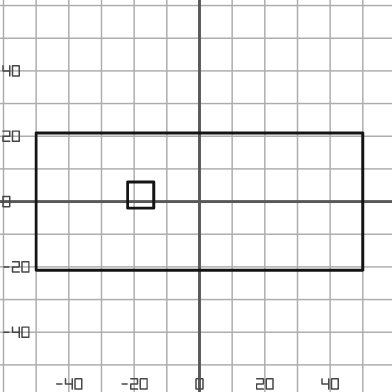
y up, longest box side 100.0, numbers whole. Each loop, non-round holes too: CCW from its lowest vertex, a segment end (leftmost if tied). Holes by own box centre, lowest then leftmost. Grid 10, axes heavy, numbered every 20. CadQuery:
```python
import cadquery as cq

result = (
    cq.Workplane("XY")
    .moveTo(-50.0, -21.0)
    .lineTo(50.0, -21.0)
    .lineTo(50.0, 21.0)
    .lineTo(-50.0, 21.0)
    .close()
    .moveTo(-22.0, -2.0)
    .lineTo(-14.0, -2.0)
    .lineTo(-14.0, 6.0)
    .lineTo(-22.0, 6.0)
    .close()
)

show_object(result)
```